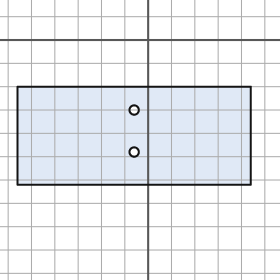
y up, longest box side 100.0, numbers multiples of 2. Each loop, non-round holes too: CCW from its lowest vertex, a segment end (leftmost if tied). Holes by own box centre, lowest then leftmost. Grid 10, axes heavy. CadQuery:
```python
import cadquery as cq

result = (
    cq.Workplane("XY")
    .moveTo(-56.0, -62.0)
    .lineTo(44.0, -62.0)
    .lineTo(44.0, -20.0)
    .lineTo(-56.0, -20.0)
    .close()
    .moveTo(-6.0, -48.0)
    .circle(2.0)
    .moveTo(-6.0, -30.0)
    .circle(2.0)
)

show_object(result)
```